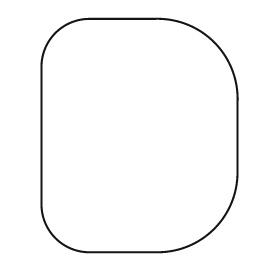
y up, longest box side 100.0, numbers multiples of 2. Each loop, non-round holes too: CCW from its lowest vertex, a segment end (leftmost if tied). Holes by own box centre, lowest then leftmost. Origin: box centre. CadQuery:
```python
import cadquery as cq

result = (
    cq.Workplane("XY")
    .moveTo(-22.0, -50.0)
    .lineTo(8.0, -50.0)
    .threePointArc((32.0, -40.0), (42.0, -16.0))
    .lineTo(42.0, 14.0)
    .threePointArc((32.0, 40.0), (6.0, 50.0))
    .lineTo(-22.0, 50.0)
    .threePointArc((-36.0, 44.0), (-42.0, 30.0))
    .lineTo(-42.0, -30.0)
    .threePointArc((-36.0, -44.0), (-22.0, -50.0))
    .close()
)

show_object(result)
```